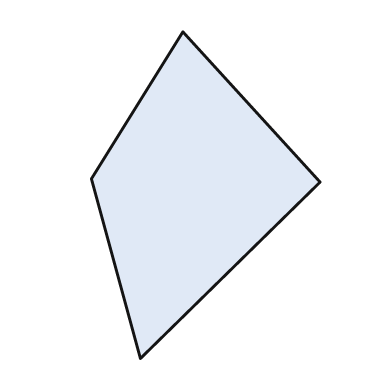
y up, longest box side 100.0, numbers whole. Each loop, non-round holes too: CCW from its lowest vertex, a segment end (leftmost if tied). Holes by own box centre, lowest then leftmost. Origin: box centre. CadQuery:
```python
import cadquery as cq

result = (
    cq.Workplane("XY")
    .moveTo(-20.0, -50.0)
    .lineTo(35.0, 4.0)
    .lineTo(-7.0, 50.0)
    .lineTo(-35.0, 5.0)
    .close()
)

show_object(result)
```